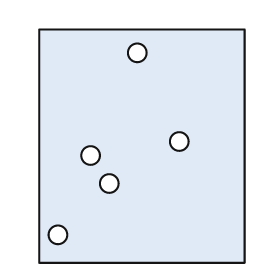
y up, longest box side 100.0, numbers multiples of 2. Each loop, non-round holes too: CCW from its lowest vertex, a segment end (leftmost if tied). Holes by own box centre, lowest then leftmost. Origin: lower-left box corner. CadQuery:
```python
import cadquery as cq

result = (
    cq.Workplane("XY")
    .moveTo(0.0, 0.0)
    .lineTo(88.0, 0.0)
    .lineTo(88.0, 100.0)
    .lineTo(0.0, 100.0)
    .close()
    .moveTo(8.0, 12.0)
    .circle(4.0)
    .moveTo(30.0, 34.0)
    .circle(4.0)
    .moveTo(22.0, 46.0)
    .circle(4.0)
    .moveTo(60.0, 52.0)
    .circle(4.0)
    .moveTo(42.0, 90.0)
    .circle(4.0)
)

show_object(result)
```